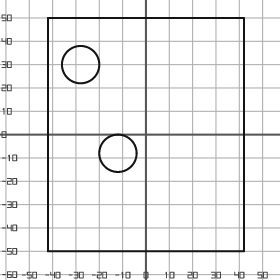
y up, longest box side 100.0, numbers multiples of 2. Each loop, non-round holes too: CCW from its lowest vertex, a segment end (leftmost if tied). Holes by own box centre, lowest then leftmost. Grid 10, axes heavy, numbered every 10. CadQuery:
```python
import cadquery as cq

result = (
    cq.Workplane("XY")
    .moveTo(-42.0, -50.0)
    .lineTo(42.0, -50.0)
    .lineTo(42.0, 50.0)
    .lineTo(-42.0, 50.0)
    .close()
    .moveTo(-12.0, -8.0)
    .circle(8.0)
    .moveTo(-28.0, 30.0)
    .circle(8.0)
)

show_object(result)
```